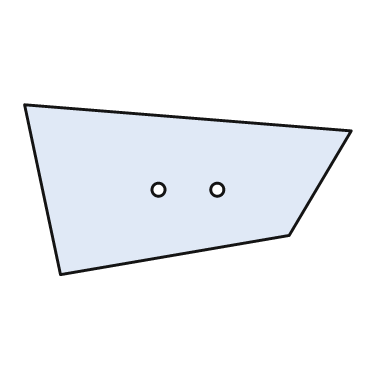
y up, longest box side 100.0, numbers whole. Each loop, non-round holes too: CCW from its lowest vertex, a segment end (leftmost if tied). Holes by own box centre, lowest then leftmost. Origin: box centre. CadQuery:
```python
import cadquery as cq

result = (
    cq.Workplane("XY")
    .moveTo(-39.0, -26.0)
    .lineTo(31.0, -14.0)
    .lineTo(50.0, 18.0)
    .lineTo(-50.0, 26.0)
    .close()
    .moveTo(-9.0, 0.0)
    .circle(2.0)
    .moveTo(9.0, 0.0)
    .circle(2.0)
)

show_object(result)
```